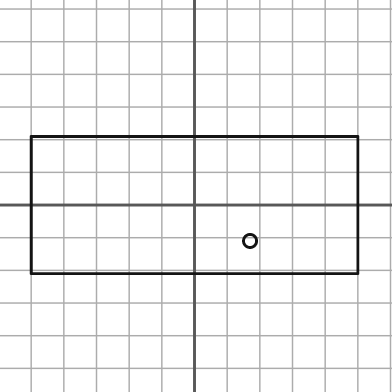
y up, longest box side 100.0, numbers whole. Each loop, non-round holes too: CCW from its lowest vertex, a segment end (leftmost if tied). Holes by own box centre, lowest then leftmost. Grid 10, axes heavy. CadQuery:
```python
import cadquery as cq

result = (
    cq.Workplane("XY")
    .moveTo(-50.0, -21.0)
    .lineTo(50.0, -21.0)
    .lineTo(50.0, 21.0)
    .lineTo(-50.0, 21.0)
    .close()
    .moveTo(17.0, -11.0)
    .circle(2.0)
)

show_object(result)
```